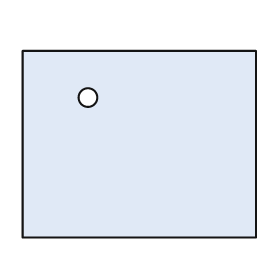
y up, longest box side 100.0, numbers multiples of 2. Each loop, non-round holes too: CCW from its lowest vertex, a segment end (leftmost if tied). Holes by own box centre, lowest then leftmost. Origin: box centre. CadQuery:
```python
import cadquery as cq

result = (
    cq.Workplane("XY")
    .moveTo(-50.0, -40.0)
    .lineTo(50.0, -40.0)
    .lineTo(50.0, 40.0)
    .lineTo(-50.0, 40.0)
    .close()
    .moveTo(-22.0, 20.0)
    .circle(4.0)
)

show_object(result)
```